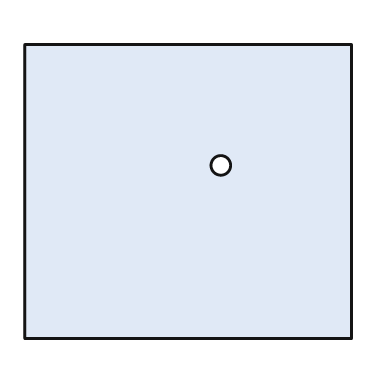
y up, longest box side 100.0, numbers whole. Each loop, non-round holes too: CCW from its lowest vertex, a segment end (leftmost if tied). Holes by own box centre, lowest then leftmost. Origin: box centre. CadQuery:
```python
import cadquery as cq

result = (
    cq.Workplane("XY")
    .moveTo(-50.0, -45.0)
    .lineTo(50.0, -45.0)
    .lineTo(50.0, 45.0)
    .lineTo(-50.0, 45.0)
    .close()
    .moveTo(10.0, 8.0)
    .circle(3.0)
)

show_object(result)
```